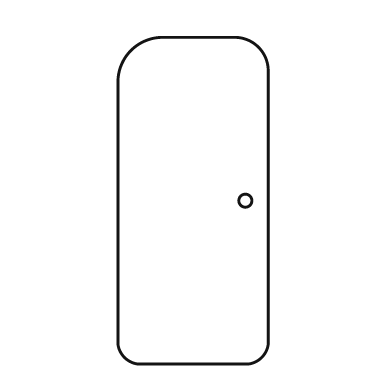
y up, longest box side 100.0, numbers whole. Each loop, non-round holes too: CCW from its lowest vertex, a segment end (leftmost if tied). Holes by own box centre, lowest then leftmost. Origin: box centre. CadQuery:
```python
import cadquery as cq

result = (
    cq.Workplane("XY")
    .moveTo(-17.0, -50.0)
    .lineTo(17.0, -50.0)
    .threePointArc((21.0, -48.0), (23.0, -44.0))
    .lineTo(23.0, 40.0)
    .threePointArc((20.0, 47.0), (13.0, 50.0))
    .lineTo(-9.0, 50.0)
    .threePointArc((-19.0, 46.0), (-23.0, 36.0))
    .lineTo(-23.0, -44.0)
    .threePointArc((-21.0, -48.0), (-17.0, -50.0))
    .close()
    .moveTo(16.0, 0.0)
    .circle(2.0)
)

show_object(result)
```